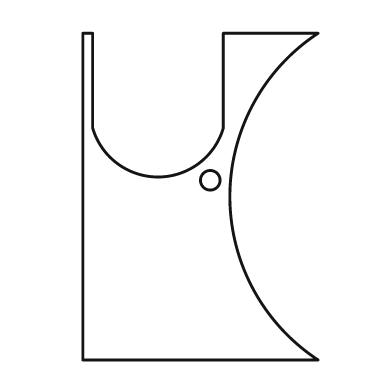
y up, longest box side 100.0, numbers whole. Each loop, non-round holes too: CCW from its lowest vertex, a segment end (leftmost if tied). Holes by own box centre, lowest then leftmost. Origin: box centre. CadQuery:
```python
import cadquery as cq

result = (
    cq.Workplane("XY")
    .moveTo(-36.0, -50.0)
    .lineTo(36.0, -50.0)
    .threePointArc((9.0, 0.0), (36.0, 50.0))
    .lineTo(7.0, 50.0)
    .lineTo(7.0, 21.0)
    .threePointArc((-13.0, 6.0), (-33.0, 21.0))
    .lineTo(-33.0, 50.0)
    .lineTo(-36.0, 50.0)
    .close()
    .moveTo(3.0, 5.0)
    .circle(3.0)
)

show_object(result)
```